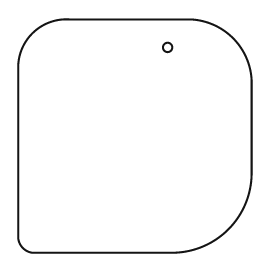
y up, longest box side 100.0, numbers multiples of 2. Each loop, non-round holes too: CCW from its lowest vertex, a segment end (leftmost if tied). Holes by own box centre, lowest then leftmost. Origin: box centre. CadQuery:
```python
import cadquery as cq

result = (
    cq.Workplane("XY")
    .moveTo(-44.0, -50.0)
    .lineTo(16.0, -50.0)
    .threePointArc((40.0, -40.0), (50.0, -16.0))
    .lineTo(50.0, 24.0)
    .threePointArc((42.0, 42.0), (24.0, 50.0))
    .lineTo(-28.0, 50.0)
    .threePointArc((-44.0, 44.0), (-50.0, 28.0))
    .lineTo(-50.0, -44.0)
    .threePointArc((-48.0, -48.0), (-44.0, -50.0))
    .close()
    .moveTo(14.0, 38.0)
    .circle(2.0)
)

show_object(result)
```